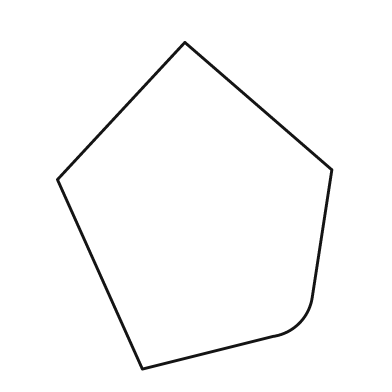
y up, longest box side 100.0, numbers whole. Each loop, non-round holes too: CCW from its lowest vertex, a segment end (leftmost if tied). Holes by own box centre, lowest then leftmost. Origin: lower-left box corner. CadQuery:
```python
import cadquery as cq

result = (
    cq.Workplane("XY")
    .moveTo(26.0, 0.0)
    .lineTo(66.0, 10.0)
    .threePointArc((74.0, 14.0), (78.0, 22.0))
    .lineTo(84.0, 61.0)
    .lineTo(39.0, 100.0)
    .lineTo(0.0, 58.0)
    .close()
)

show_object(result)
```